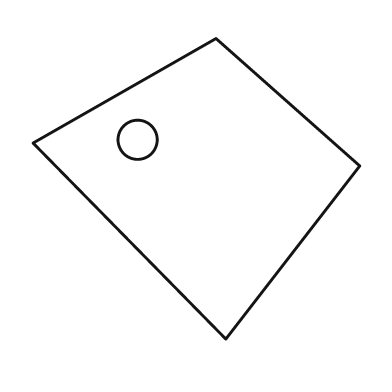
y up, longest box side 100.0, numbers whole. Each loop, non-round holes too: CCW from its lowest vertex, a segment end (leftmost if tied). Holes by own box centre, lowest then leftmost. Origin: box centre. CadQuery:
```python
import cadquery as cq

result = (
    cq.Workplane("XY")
    .moveTo(9.0, -46.0)
    .lineTo(50.0, 7.0)
    .lineTo(6.0, 46.0)
    .lineTo(-50.0, 14.0)
    .close()
    .moveTo(-18.0, 15.0)
    .circle(6.0)
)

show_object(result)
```